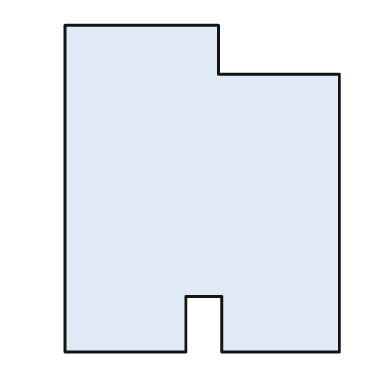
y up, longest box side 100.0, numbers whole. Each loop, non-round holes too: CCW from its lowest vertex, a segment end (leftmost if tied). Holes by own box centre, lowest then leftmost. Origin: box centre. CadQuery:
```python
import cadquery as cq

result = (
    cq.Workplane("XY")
    .moveTo(-42.0, -50.0)
    .lineTo(-5.0, -50.0)
    .lineTo(-5.0, -33.0)
    .lineTo(6.0, -33.0)
    .lineTo(6.0, -50.0)
    .lineTo(42.0, -50.0)
    .lineTo(42.0, 35.0)
    .lineTo(5.0, 35.0)
    .lineTo(5.0, 50.0)
    .lineTo(-42.0, 50.0)
    .close()
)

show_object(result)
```